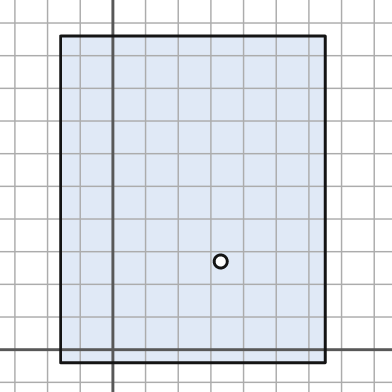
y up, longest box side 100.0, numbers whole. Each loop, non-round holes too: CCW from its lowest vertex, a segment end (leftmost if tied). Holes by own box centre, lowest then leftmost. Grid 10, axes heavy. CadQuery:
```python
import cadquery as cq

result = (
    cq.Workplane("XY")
    .moveTo(-16.0, -4.0)
    .lineTo(65.0, -4.0)
    .lineTo(65.0, 96.0)
    .lineTo(-16.0, 96.0)
    .close()
    .moveTo(33.0, 27.0)
    .circle(2.0)
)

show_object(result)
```